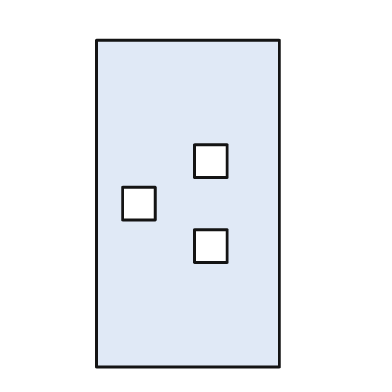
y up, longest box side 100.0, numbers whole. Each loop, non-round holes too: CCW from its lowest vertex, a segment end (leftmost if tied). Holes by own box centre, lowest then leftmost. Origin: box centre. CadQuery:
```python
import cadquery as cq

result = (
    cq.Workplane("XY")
    .moveTo(-28.0, -50.0)
    .lineTo(28.0, -50.0)
    .lineTo(28.0, 50.0)
    .lineTo(-28.0, 50.0)
    .close()
    .moveTo(2.0, -18.0)
    .lineTo(12.0, -18.0)
    .lineTo(12.0, -8.0)
    .lineTo(2.0, -8.0)
    .close()
    .moveTo(-20.0, -5.0)
    .lineTo(-10.0, -5.0)
    .lineTo(-10.0, 5.0)
    .lineTo(-20.0, 5.0)
    .close()
    .moveTo(2.0, 8.0)
    .lineTo(12.0, 8.0)
    .lineTo(12.0, 18.0)
    .lineTo(2.0, 18.0)
    .close()
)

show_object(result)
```